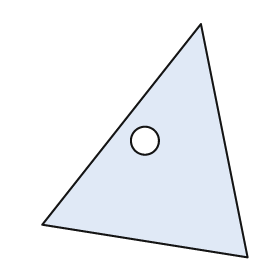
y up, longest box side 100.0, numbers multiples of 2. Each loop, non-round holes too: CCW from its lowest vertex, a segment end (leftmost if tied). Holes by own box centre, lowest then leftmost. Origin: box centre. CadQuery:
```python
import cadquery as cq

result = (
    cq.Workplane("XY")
    .moveTo(44.0, -50.0)
    .lineTo(24.0, 50.0)
    .lineTo(-44.0, -36.0)
    .close()
    .moveTo(0.0, 0.0)
    .circle(6.0)
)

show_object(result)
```